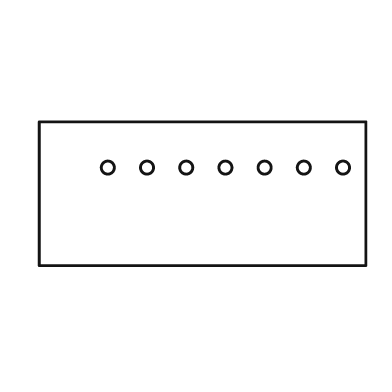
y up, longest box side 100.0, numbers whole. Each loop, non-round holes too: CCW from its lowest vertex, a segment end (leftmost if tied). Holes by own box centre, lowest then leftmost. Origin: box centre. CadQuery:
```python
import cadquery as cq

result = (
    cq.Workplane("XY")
    .moveTo(-50.0, -22.0)
    .lineTo(50.0, -22.0)
    .lineTo(50.0, 22.0)
    .lineTo(-50.0, 22.0)
    .close()
    .moveTo(-29.0, 8.0)
    .circle(2.0)
    .moveTo(-17.0, 8.0)
    .circle(2.0)
    .moveTo(-5.0, 8.0)
    .circle(2.0)
    .moveTo(7.0, 8.0)
    .circle(2.0)
    .moveTo(19.0, 8.0)
    .circle(2.0)
    .moveTo(31.0, 8.0)
    .circle(2.0)
    .moveTo(43.0, 8.0)
    .circle(2.0)
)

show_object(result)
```